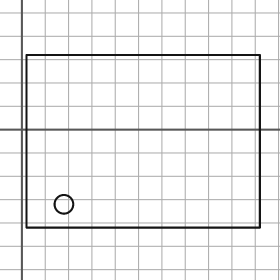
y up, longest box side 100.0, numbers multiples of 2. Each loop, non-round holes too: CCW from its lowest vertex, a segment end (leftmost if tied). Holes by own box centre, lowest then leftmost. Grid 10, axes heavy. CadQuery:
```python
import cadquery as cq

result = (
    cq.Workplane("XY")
    .moveTo(2.0, -42.0)
    .lineTo(102.0, -42.0)
    .lineTo(102.0, 32.0)
    .lineTo(2.0, 32.0)
    .close()
    .moveTo(18.0, -32.0)
    .circle(4.0)
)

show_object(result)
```